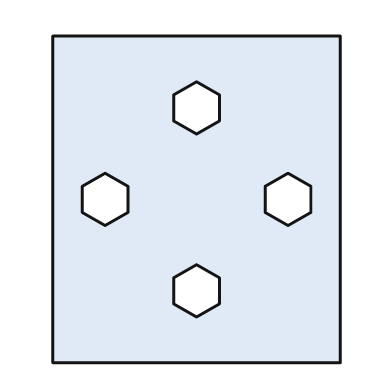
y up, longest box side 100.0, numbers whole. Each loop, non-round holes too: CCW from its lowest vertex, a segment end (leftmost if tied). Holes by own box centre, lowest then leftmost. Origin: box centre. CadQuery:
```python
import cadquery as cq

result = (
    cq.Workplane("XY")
    .moveTo(-44.0, -50.0)
    .lineTo(44.0, -50.0)
    .lineTo(44.0, 50.0)
    .lineTo(-44.0, 50.0)
    .close()
    .moveTo(0.0, -36.0)
    .lineTo(7.0, -32.0)
    .lineTo(7.0, -24.0)
    .lineTo(0.0, -20.0)
    .lineTo(-7.0, -24.0)
    .lineTo(-7.0, -32.0)
    .close()
    .moveTo(-28.0, -8.0)
    .lineTo(-21.0, -4.0)
    .lineTo(-21.0, 4.0)
    .lineTo(-28.0, 8.0)
    .lineTo(-35.0, 4.0)
    .lineTo(-35.0, -4.0)
    .close()
    .moveTo(28.0, -8.0)
    .lineTo(35.0, -4.0)
    .lineTo(35.0, 4.0)
    .lineTo(28.0, 8.0)
    .lineTo(21.0, 4.0)
    .lineTo(21.0, -4.0)
    .close()
    .moveTo(0.0, 20.0)
    .lineTo(7.0, 24.0)
    .lineTo(7.0, 32.0)
    .lineTo(0.0, 36.0)
    .lineTo(-7.0, 32.0)
    .lineTo(-7.0, 24.0)
    .close()
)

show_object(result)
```